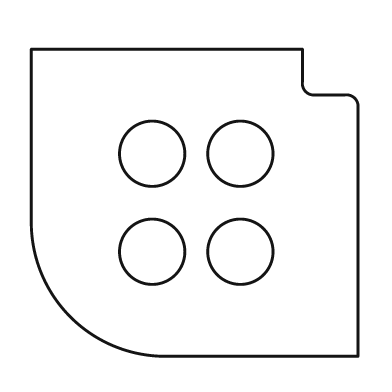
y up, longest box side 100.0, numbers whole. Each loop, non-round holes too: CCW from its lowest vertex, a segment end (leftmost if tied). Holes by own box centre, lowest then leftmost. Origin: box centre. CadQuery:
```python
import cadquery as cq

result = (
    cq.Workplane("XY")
    .moveTo(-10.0, -47.0)
    .lineTo(50.0, -47.0)
    .lineTo(50.0, 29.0)
    .threePointArc((49.0, 32.0), (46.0, 33.0))
    .lineTo(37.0, 33.0)
    .threePointArc((34.0, 34.0), (33.0, 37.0))
    .lineTo(33.0, 47.0)
    .lineTo(-50.0, 47.0)
    .lineTo(-50.0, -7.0)
    .threePointArc((-38.0, -35.0), (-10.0, -47.0))
    .close()
    .moveTo(-13.0, -15.0)
    .circle(10.0)
    .moveTo(14.0, -15.0)
    .circle(10.0)
    .moveTo(-13.0, 15.0)
    .circle(10.0)
    .moveTo(14.0, 15.0)
    .circle(10.0)
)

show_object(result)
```